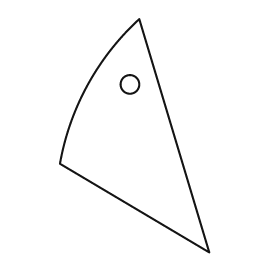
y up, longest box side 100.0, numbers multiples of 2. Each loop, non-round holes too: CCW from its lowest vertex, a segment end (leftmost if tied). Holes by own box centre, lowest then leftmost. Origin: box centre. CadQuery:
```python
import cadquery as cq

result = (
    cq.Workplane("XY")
    .moveTo(32.0, -50.0)
    .lineTo(2.0, 50.0)
    .threePointArc((-20.0, 22.0), (-32.0, -12.0))
    .close()
    .moveTo(-2.0, 22.0)
    .circle(4.0)
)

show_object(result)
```